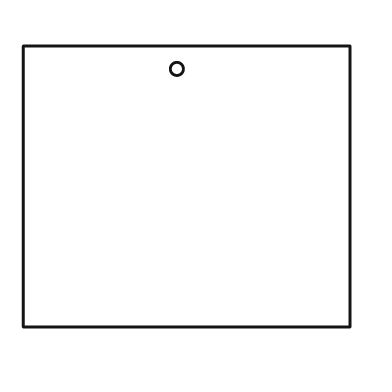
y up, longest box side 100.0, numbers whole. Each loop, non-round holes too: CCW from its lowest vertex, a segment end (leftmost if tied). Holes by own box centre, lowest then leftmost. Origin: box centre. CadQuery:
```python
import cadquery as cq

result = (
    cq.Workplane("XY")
    .moveTo(-50.0, -43.0)
    .lineTo(50.0, -43.0)
    .lineTo(50.0, 43.0)
    .lineTo(-50.0, 43.0)
    .close()
    .moveTo(-3.0, 36.0)
    .circle(2.0)
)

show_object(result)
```